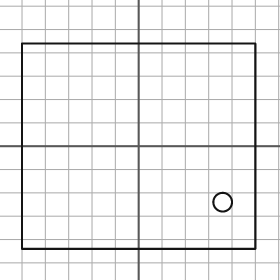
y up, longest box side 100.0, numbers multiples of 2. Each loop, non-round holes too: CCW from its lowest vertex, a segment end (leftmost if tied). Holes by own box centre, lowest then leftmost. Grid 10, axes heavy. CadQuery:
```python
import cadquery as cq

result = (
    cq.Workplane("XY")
    .moveTo(-50.0, -44.0)
    .lineTo(50.0, -44.0)
    .lineTo(50.0, 44.0)
    .lineTo(-50.0, 44.0)
    .close()
    .moveTo(36.0, -24.0)
    .circle(4.0)
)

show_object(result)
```